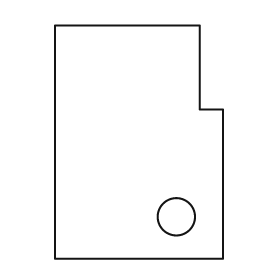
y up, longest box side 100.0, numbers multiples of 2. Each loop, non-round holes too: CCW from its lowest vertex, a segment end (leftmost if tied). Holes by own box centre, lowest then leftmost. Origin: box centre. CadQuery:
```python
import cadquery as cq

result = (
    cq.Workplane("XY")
    .moveTo(-36.0, -50.0)
    .lineTo(36.0, -50.0)
    .lineTo(36.0, 14.0)
    .lineTo(26.0, 14.0)
    .lineTo(26.0, 50.0)
    .lineTo(-36.0, 50.0)
    .close()
    .moveTo(16.0, -32.0)
    .circle(8.0)
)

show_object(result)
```